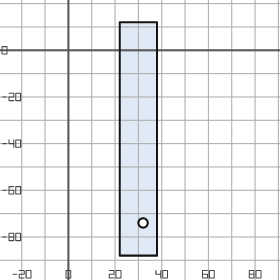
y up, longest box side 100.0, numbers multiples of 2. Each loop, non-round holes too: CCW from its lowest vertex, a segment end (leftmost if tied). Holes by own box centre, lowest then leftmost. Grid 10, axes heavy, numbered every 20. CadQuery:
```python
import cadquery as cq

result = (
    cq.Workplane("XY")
    .moveTo(22.0, -88.0)
    .lineTo(38.0, -88.0)
    .lineTo(38.0, 12.0)
    .lineTo(22.0, 12.0)
    .close()
    .moveTo(32.0, -74.0)
    .circle(2.0)
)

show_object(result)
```